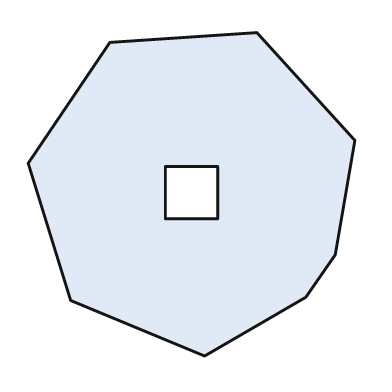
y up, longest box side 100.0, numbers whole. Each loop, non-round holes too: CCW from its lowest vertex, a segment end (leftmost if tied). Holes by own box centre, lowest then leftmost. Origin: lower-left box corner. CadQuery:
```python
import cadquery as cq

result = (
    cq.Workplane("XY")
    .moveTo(54.0, 0.0)
    .lineTo(85.0, 18.0)
    .lineTo(94.0, 31.0)
    .lineTo(100.0, 66.0)
    .lineTo(70.0, 99.0)
    .lineTo(25.0, 96.0)
    .lineTo(0.0, 59.0)
    .lineTo(13.0, 17.0)
    .close()
    .moveTo(42.0, 42.0)
    .lineTo(58.0, 42.0)
    .lineTo(58.0, 58.0)
    .lineTo(42.0, 58.0)
    .close()
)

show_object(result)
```